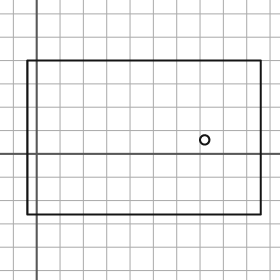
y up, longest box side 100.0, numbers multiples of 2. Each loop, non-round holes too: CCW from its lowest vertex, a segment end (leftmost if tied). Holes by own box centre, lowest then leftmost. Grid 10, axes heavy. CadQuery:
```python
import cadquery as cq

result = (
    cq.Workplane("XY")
    .moveTo(-4.0, -26.0)
    .lineTo(96.0, -26.0)
    .lineTo(96.0, 40.0)
    .lineTo(-4.0, 40.0)
    .close()
    .moveTo(72.0, 6.0)
    .circle(2.0)
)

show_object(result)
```